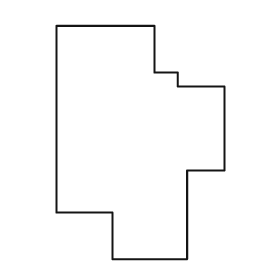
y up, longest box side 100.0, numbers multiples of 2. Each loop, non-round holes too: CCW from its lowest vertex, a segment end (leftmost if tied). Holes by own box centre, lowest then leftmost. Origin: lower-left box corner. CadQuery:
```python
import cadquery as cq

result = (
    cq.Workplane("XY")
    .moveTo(24.0, 0.0)
    .lineTo(56.0, 0.0)
    .lineTo(56.0, 38.0)
    .lineTo(72.0, 38.0)
    .lineTo(72.0, 74.0)
    .lineTo(52.0, 74.0)
    .lineTo(52.0, 80.0)
    .lineTo(42.0, 80.0)
    .lineTo(42.0, 100.0)
    .lineTo(0.0, 100.0)
    .lineTo(0.0, 20.0)
    .lineTo(24.0, 20.0)
    .close()
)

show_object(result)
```